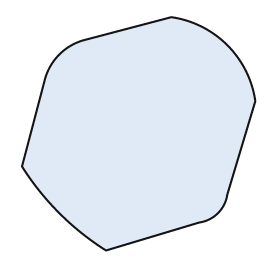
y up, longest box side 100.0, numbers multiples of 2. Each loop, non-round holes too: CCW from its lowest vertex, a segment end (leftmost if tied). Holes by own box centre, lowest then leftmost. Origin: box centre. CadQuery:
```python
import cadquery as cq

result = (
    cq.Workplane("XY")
    .moveTo(-14.0, -50.0)
    .lineTo(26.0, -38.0)
    .threePointArc((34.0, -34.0), (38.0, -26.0))
    .lineTo(50.0, 14.0)
    .threePointArc((38.0, 38.0), (14.0, 50.0))
    .lineTo(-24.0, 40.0)
    .threePointArc((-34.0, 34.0), (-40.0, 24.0))
    .lineTo(-50.0, -14.0)
    .threePointArc((-34.0, -34.0), (-14.0, -50.0))
    .close()
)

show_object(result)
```